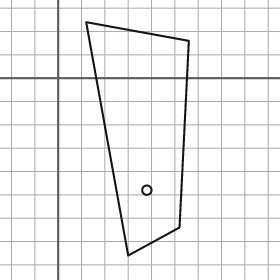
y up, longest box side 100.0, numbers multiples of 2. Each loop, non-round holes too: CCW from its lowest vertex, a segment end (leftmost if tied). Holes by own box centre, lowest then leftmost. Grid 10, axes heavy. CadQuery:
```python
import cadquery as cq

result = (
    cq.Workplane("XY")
    .moveTo(30.0, -76.0)
    .lineTo(52.0, -64.0)
    .lineTo(56.0, 16.0)
    .lineTo(12.0, 24.0)
    .close()
    .moveTo(38.0, -48.0)
    .circle(2.0)
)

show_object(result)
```